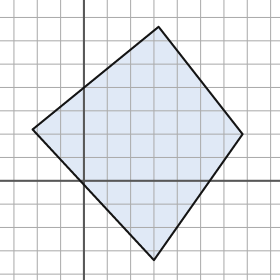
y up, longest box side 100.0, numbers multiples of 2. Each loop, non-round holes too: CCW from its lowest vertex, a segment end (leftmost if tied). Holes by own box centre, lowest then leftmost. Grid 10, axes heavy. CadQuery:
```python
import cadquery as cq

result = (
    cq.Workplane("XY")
    .moveTo(30.0, -34.0)
    .lineTo(68.0, 20.0)
    .lineTo(32.0, 66.0)
    .lineTo(-22.0, 22.0)
    .close()
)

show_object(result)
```